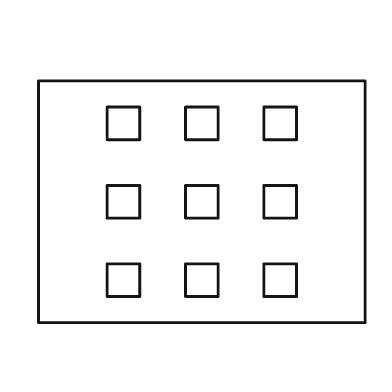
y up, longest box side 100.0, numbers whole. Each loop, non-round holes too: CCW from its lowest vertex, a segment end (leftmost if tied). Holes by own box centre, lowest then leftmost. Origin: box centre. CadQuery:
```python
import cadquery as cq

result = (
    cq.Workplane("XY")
    .moveTo(-50.0, -37.0)
    .lineTo(50.0, -37.0)
    .lineTo(50.0, 37.0)
    .lineTo(-50.0, 37.0)
    .close()
    .moveTo(-29.0, -29.0)
    .lineTo(-19.0, -29.0)
    .lineTo(-19.0, -19.0)
    .lineTo(-29.0, -19.0)
    .close()
    .moveTo(-5.0, -29.0)
    .lineTo(5.0, -29.0)
    .lineTo(5.0, -19.0)
    .lineTo(-5.0, -19.0)
    .close()
    .moveTo(19.0, -29.0)
    .lineTo(29.0, -29.0)
    .lineTo(29.0, -19.0)
    .lineTo(19.0, -19.0)
    .close()
    .moveTo(-29.0, -5.0)
    .lineTo(-19.0, -5.0)
    .lineTo(-19.0, 5.0)
    .lineTo(-29.0, 5.0)
    .close()
    .moveTo(-5.0, -5.0)
    .lineTo(5.0, -5.0)
    .lineTo(5.0, 5.0)
    .lineTo(-5.0, 5.0)
    .close()
    .moveTo(19.0, -5.0)
    .lineTo(29.0, -5.0)
    .lineTo(29.0, 5.0)
    .lineTo(19.0, 5.0)
    .close()
    .moveTo(-29.0, 19.0)
    .lineTo(-19.0, 19.0)
    .lineTo(-19.0, 29.0)
    .lineTo(-29.0, 29.0)
    .close()
    .moveTo(-5.0, 19.0)
    .lineTo(5.0, 19.0)
    .lineTo(5.0, 29.0)
    .lineTo(-5.0, 29.0)
    .close()
    .moveTo(19.0, 19.0)
    .lineTo(29.0, 19.0)
    .lineTo(29.0, 29.0)
    .lineTo(19.0, 29.0)
    .close()
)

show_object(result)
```